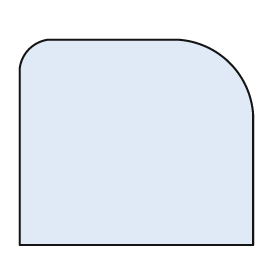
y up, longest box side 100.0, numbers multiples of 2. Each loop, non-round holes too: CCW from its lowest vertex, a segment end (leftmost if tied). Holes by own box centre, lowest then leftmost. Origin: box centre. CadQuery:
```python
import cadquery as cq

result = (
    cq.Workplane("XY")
    .moveTo(-50.0, -44.0)
    .lineTo(50.0, -44.0)
    .lineTo(50.0, 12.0)
    .threePointArc((40.0, 34.0), (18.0, 44.0))
    .lineTo(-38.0, 44.0)
    .threePointArc((-46.0, 40.0), (-50.0, 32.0))
    .close()
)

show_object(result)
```